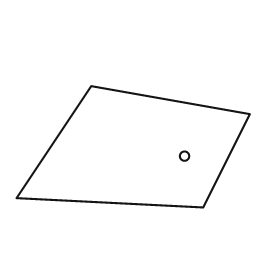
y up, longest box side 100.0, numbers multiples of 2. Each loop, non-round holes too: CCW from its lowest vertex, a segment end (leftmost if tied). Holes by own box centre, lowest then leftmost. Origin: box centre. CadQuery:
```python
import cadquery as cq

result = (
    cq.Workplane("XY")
    .moveTo(30.0, -26.0)
    .lineTo(50.0, 14.0)
    .lineTo(-18.0, 26.0)
    .lineTo(-50.0, -22.0)
    .close()
    .moveTo(22.0, -4.0)
    .circle(2.0)
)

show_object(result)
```